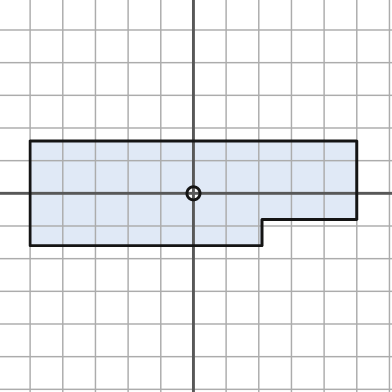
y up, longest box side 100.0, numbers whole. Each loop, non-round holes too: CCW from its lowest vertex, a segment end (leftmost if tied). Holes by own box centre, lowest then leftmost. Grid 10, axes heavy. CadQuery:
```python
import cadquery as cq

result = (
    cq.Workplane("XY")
    .moveTo(-50.0, -16.0)
    .lineTo(21.0, -16.0)
    .lineTo(21.0, -8.0)
    .lineTo(50.0, -8.0)
    .lineTo(50.0, 16.0)
    .lineTo(-50.0, 16.0)
    .close()
    .moveTo(0.0, 0.0)
    .circle(2.0)
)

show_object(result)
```